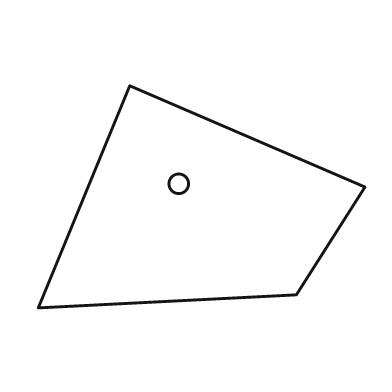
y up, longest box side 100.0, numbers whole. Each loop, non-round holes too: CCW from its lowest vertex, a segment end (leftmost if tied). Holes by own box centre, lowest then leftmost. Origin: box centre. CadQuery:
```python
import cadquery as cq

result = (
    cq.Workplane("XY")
    .moveTo(-50.0, -34.0)
    .lineTo(29.0, -30.0)
    .lineTo(50.0, 3.0)
    .lineTo(-22.0, 34.0)
    .close()
    .moveTo(-7.0, 4.0)
    .circle(3.0)
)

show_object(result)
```